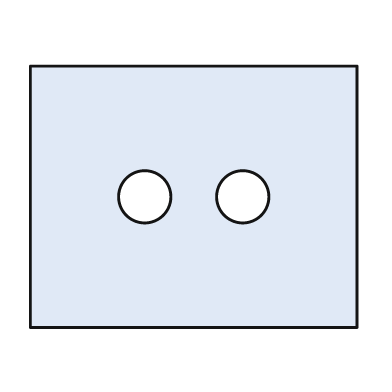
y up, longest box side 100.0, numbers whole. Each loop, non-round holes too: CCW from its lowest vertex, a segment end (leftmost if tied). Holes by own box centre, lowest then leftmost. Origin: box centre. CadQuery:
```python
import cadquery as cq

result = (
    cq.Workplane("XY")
    .moveTo(-50.0, -40.0)
    .lineTo(50.0, -40.0)
    .lineTo(50.0, 40.0)
    .lineTo(-50.0, 40.0)
    .close()
    .moveTo(-15.0, 0.0)
    .circle(8.0)
    .moveTo(15.0, 0.0)
    .circle(8.0)
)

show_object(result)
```